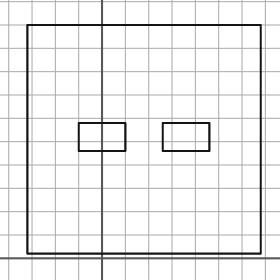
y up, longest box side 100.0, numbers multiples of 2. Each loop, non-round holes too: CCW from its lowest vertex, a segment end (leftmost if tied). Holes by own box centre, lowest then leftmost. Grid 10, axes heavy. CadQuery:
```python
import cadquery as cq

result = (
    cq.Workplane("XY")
    .moveTo(-32.0, 2.0)
    .lineTo(68.0, 2.0)
    .lineTo(68.0, 100.0)
    .lineTo(-32.0, 100.0)
    .close()
    .moveTo(-10.0, 46.0)
    .lineTo(10.0, 46.0)
    .lineTo(10.0, 58.0)
    .lineTo(-10.0, 58.0)
    .close()
    .moveTo(26.0, 46.0)
    .lineTo(46.0, 46.0)
    .lineTo(46.0, 58.0)
    .lineTo(26.0, 58.0)
    .close()
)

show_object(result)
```